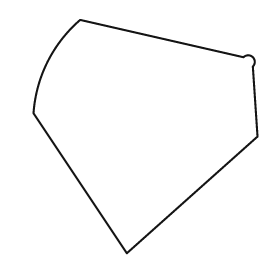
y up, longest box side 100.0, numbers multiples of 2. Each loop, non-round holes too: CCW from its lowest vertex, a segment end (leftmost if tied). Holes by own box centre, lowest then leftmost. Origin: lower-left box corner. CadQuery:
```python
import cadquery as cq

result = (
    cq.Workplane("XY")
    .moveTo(40.0, 0.0)
    .lineTo(96.0, 50.0)
    .lineTo(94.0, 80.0)
    .threePointArc((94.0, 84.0), (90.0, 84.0))
    .lineTo(20.0, 100.0)
    .threePointArc((6.0, 82.0), (0.0, 60.0))
    .close()
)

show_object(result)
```